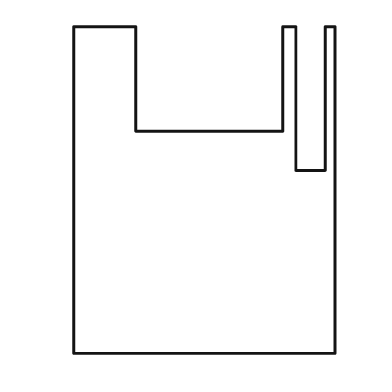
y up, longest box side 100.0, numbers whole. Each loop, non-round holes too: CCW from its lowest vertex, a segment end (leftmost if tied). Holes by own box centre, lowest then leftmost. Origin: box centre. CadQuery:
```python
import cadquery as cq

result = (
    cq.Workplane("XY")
    .moveTo(-40.0, -50.0)
    .lineTo(40.0, -50.0)
    .lineTo(40.0, 50.0)
    .lineTo(37.0, 50.0)
    .lineTo(37.0, 6.0)
    .lineTo(28.0, 6.0)
    .lineTo(28.0, 50.0)
    .lineTo(24.0, 50.0)
    .lineTo(24.0, 18.0)
    .lineTo(-21.0, 18.0)
    .lineTo(-21.0, 50.0)
    .lineTo(-40.0, 50.0)
    .close()
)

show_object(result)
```